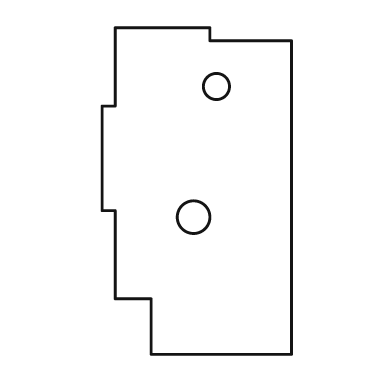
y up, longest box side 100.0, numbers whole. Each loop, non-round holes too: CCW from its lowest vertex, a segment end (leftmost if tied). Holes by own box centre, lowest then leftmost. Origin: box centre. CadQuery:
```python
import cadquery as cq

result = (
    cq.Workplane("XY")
    .moveTo(-14.0, -50.0)
    .lineTo(29.0, -50.0)
    .lineTo(29.0, 46.0)
    .lineTo(4.0, 46.0)
    .lineTo(4.0, 50.0)
    .lineTo(-25.0, 50.0)
    .lineTo(-25.0, 26.0)
    .lineTo(-29.0, 26.0)
    .lineTo(-29.0, -6.0)
    .lineTo(-25.0, -6.0)
    .lineTo(-25.0, -33.0)
    .lineTo(-14.0, -33.0)
    .close()
    .moveTo(-1.0, -8.0)
    .circle(5.0)
    .moveTo(6.0, 32.0)
    .circle(4.0)
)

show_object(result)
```